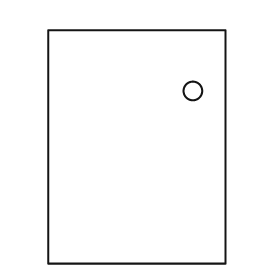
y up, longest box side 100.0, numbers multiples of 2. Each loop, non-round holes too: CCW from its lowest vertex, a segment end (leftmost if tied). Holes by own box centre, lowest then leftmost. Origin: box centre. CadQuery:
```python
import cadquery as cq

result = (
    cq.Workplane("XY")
    .moveTo(-38.0, -50.0)
    .lineTo(38.0, -50.0)
    .lineTo(38.0, 50.0)
    .lineTo(-38.0, 50.0)
    .close()
    .moveTo(24.0, 24.0)
    .circle(4.0)
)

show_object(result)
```